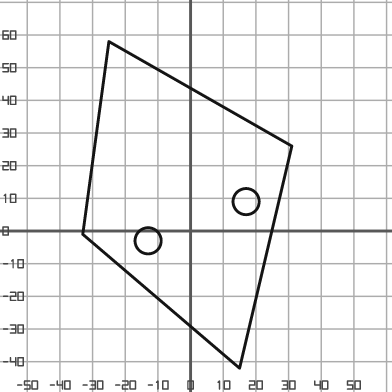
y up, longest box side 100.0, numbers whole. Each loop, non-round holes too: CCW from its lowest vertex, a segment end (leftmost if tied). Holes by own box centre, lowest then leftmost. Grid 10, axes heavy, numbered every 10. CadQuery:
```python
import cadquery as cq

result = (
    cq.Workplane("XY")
    .moveTo(15.0, -42.0)
    .lineTo(31.0, 26.0)
    .lineTo(-25.0, 58.0)
    .lineTo(-33.0, -1.0)
    .close()
    .moveTo(-13.0, -3.0)
    .circle(4.0)
    .moveTo(17.0, 9.0)
    .circle(4.0)
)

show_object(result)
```